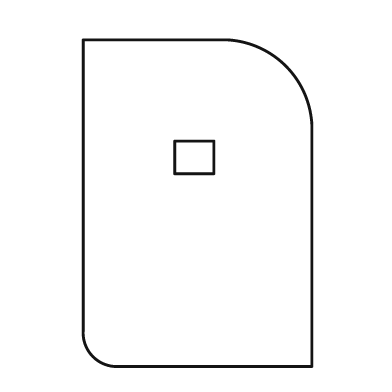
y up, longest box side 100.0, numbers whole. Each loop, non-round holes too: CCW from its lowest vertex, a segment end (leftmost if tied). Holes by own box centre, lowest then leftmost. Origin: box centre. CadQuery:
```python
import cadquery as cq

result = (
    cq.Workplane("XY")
    .moveTo(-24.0, -50.0)
    .lineTo(35.0, -50.0)
    .lineTo(35.0, 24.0)
    .threePointArc((27.0, 42.0), (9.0, 50.0))
    .lineTo(-35.0, 50.0)
    .lineTo(-35.0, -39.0)
    .threePointArc((-32.0, -47.0), (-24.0, -50.0))
    .close()
    .moveTo(-7.0, 9.0)
    .lineTo(5.0, 9.0)
    .lineTo(5.0, 19.0)
    .lineTo(-7.0, 19.0)
    .close()
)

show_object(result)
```